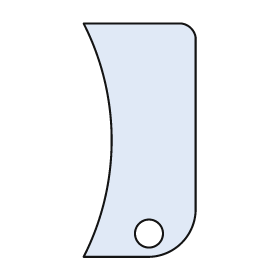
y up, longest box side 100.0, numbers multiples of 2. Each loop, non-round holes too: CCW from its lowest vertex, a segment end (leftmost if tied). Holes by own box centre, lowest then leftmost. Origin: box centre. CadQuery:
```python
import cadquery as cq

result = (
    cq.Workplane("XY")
    .moveTo(-24.0, -50.0)
    .lineTo(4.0, -50.0)
    .threePointArc((18.0, -44.0), (24.0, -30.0))
    .lineTo(24.0, 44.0)
    .threePointArc((22.0, 48.0), (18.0, 50.0))
    .lineTo(-24.0, 50.0)
    .threePointArc((-12.0, 0.0), (-24.0, -50.0))
    .close()
    .moveTo(4.0, -40.0)
    .circle(6.0)
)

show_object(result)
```